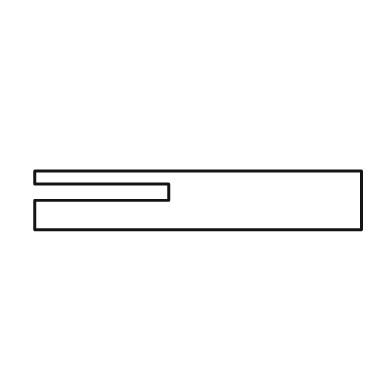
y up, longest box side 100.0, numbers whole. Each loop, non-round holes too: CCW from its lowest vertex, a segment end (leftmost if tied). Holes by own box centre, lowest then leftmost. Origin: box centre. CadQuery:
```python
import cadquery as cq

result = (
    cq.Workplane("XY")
    .moveTo(-50.0, -9.0)
    .lineTo(50.0, -9.0)
    .lineTo(50.0, 9.0)
    .lineTo(-50.0, 9.0)
    .lineTo(-50.0, 5.0)
    .lineTo(-9.0, 5.0)
    .lineTo(-9.0, 0.0)
    .lineTo(-50.0, 0.0)
    .close()
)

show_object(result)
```